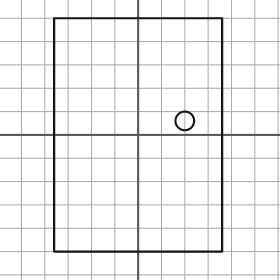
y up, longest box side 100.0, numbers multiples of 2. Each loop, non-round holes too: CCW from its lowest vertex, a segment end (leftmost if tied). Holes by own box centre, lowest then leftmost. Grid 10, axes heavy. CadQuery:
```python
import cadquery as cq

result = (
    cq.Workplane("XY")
    .moveTo(-36.0, -50.0)
    .lineTo(36.0, -50.0)
    .lineTo(36.0, 50.0)
    .lineTo(-36.0, 50.0)
    .close()
    .moveTo(20.0, 6.0)
    .circle(4.0)
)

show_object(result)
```